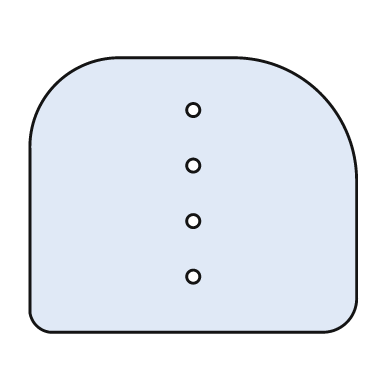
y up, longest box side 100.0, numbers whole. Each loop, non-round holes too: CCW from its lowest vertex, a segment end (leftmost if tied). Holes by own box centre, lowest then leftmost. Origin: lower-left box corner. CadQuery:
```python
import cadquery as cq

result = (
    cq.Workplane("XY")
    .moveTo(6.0, 0.0)
    .lineTo(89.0, 0.0)
    .threePointArc((97.0, 3.0), (100.0, 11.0))
    .lineTo(100.0, 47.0)
    .threePointArc((89.0, 73.0), (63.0, 84.0))
    .lineTo(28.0, 84.0)
    .threePointArc((8.0, 76.0), (0.0, 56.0))
    .lineTo(0.0, 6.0)
    .threePointArc((2.0, 2.0), (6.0, 0.0))
    .close()
    .moveTo(50.0, 17.0)
    .circle(2.0)
    .moveTo(50.0, 34.0)
    .circle(2.0)
    .moveTo(50.0, 51.0)
    .circle(2.0)
    .moveTo(50.0, 68.0)
    .circle(2.0)
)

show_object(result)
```